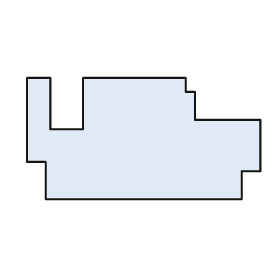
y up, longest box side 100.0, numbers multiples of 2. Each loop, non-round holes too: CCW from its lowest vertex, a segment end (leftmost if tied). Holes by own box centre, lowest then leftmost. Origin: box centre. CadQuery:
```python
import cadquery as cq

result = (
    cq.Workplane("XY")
    .moveTo(-42.0, -26.0)
    .lineTo(42.0, -26.0)
    .lineTo(42.0, -14.0)
    .lineTo(50.0, -14.0)
    .lineTo(50.0, 8.0)
    .lineTo(22.0, 8.0)
    .lineTo(22.0, 20.0)
    .lineTo(18.0, 20.0)
    .lineTo(18.0, 26.0)
    .lineTo(-26.0, 26.0)
    .lineTo(-26.0, 4.0)
    .lineTo(-40.0, 4.0)
    .lineTo(-40.0, 26.0)
    .lineTo(-50.0, 26.0)
    .lineTo(-50.0, -10.0)
    .lineTo(-42.0, -10.0)
    .close()
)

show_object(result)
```